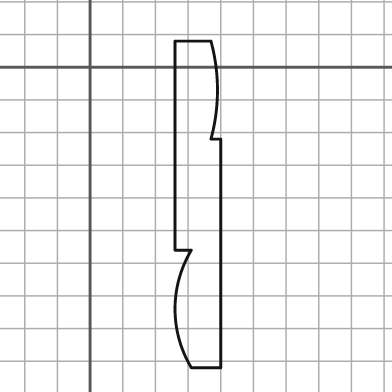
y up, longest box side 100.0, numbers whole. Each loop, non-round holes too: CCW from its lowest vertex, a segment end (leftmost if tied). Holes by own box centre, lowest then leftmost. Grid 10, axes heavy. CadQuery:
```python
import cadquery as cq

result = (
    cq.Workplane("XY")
    .moveTo(31.0, -92.0)
    .lineTo(40.0, -92.0)
    .lineTo(40.0, -22.0)
    .lineTo(37.0, -22.0)
    .threePointArc((39.0, -7.0), (37.0, 8.0))
    .lineTo(26.0, 8.0)
    .lineTo(26.0, -56.0)
    .lineTo(31.0, -56.0)
    .threePointArc((26.0, -74.0), (31.0, -92.0))
    .close()
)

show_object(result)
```